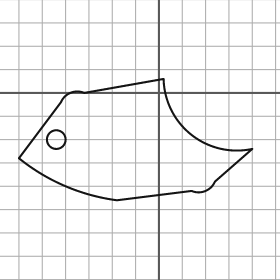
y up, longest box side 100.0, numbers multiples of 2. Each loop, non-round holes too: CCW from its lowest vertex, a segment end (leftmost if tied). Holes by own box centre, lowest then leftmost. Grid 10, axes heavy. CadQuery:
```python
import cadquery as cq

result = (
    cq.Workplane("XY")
    .moveTo(-18.0, -46.0)
    .lineTo(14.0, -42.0)
    .threePointArc((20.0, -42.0), (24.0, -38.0))
    .lineTo(40.0, -24.0)
    .threePointArc((14.0, -18.0), (2.0, 6.0))
    .lineTo(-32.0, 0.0)
    .threePointArc((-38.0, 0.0), (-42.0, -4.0))
    .lineTo(-60.0, -28.0)
    .threePointArc((-40.0, -40.0), (-18.0, -46.0))
    .close()
    .moveTo(-44.0, -20.0)
    .circle(4.0)
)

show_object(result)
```